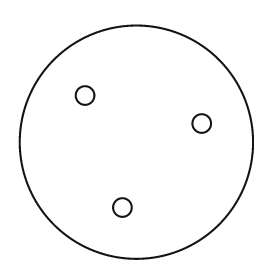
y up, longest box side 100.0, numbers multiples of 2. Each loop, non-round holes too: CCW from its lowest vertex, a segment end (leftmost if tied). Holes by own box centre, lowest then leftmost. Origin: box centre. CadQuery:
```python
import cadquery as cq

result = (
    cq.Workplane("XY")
    .moveTo(0.0, 0.0)
    .circle(50.0)
    .moveTo(-6.0, -28.0)
    .circle(4.0)
    .moveTo(28.0, 8.0)
    .circle(4.0)
    .moveTo(-22.0, 20.0)
    .circle(4.0)
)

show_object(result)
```